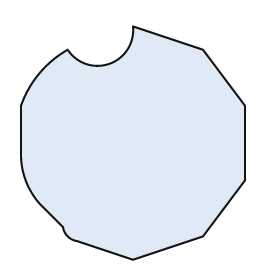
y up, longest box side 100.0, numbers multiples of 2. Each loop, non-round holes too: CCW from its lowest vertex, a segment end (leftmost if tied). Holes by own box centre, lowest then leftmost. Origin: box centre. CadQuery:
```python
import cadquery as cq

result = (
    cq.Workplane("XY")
    .moveTo(0.0, -50.0)
    .lineTo(30.0, -40.0)
    .lineTo(48.0, -16.0)
    .lineTo(48.0, 16.0)
    .lineTo(30.0, 40.0)
    .lineTo(0.0, 50.0)
    .threePointArc((-10.0, 34.0), (-28.0, 40.0))
    .threePointArc((-40.0, 30.0), (-48.0, 16.0))
    .lineTo(-48.0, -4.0)
    .threePointArc((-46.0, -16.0), (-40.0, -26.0))
    .lineTo(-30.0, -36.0)
    .threePointArc((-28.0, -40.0), (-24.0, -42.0))
    .close()
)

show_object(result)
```